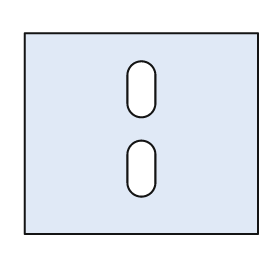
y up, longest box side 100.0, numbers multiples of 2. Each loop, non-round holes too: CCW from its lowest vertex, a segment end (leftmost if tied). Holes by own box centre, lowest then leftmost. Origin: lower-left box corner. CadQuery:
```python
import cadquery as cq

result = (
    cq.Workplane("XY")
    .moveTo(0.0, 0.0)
    .lineTo(100.0, 0.0)
    .lineTo(100.0, 86.0)
    .lineTo(0.0, 86.0)
    .close()
    .moveTo(44.0, 22.0)
    .threePointArc((50.0, 16.0), (56.0, 22.0))
    .lineTo(56.0, 34.0)
    .threePointArc((50.0, 40.0), (44.0, 34.0))
    .close()
    .moveTo(44.0, 56.0)
    .threePointArc((50.0, 50.0), (56.0, 56.0))
    .lineTo(56.0, 68.0)
    .threePointArc((50.0, 74.0), (44.0, 68.0))
    .close()
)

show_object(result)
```